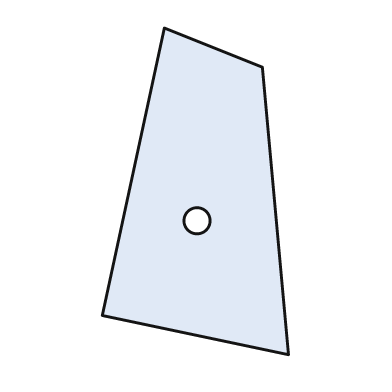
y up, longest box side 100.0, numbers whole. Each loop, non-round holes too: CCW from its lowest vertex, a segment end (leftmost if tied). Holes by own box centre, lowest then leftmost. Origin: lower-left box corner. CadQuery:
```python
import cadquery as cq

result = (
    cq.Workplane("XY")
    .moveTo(57.0, 0.0)
    .lineTo(49.0, 88.0)
    .lineTo(19.0, 100.0)
    .lineTo(0.0, 12.0)
    .close()
    .moveTo(29.0, 41.0)
    .circle(4.0)
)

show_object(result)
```